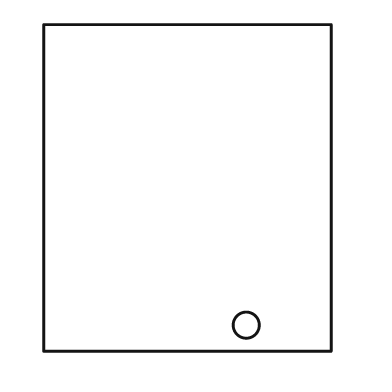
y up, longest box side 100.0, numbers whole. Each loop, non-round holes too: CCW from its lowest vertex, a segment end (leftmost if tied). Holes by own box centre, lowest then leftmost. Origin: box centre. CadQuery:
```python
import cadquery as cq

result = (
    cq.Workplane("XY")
    .moveTo(-44.0, -50.0)
    .lineTo(44.0, -50.0)
    .lineTo(44.0, 50.0)
    .lineTo(-44.0, 50.0)
    .close()
    .moveTo(18.0, -42.0)
    .circle(4.0)
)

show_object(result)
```